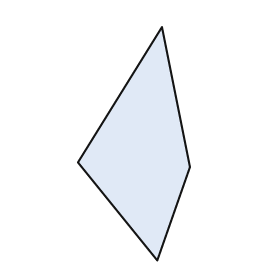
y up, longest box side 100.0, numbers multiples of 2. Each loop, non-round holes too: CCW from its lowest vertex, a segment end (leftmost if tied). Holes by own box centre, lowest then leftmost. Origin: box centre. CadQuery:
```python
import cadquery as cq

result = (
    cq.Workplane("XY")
    .moveTo(10.0, -50.0)
    .lineTo(24.0, -10.0)
    .lineTo(12.0, 50.0)
    .lineTo(-24.0, -8.0)
    .close()
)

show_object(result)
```